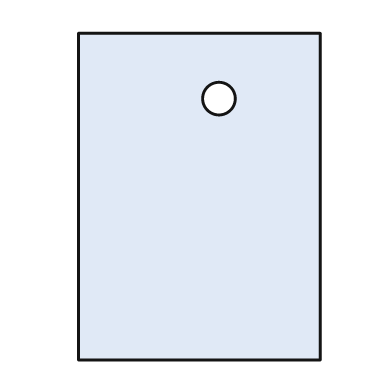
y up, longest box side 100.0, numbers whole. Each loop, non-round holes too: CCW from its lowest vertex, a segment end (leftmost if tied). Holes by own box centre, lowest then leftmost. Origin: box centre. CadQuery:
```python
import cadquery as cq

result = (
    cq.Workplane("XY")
    .moveTo(-37.0, -50.0)
    .lineTo(37.0, -50.0)
    .lineTo(37.0, 50.0)
    .lineTo(-37.0, 50.0)
    .close()
    .moveTo(6.0, 30.0)
    .circle(5.0)
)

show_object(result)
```